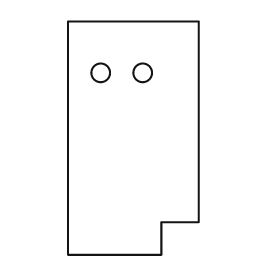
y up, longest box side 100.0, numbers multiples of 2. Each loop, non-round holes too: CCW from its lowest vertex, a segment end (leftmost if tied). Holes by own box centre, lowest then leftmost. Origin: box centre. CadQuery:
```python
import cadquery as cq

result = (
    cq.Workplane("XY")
    .moveTo(-28.0, -50.0)
    .lineTo(12.0, -50.0)
    .lineTo(12.0, -36.0)
    .lineTo(28.0, -36.0)
    .lineTo(28.0, 50.0)
    .lineTo(-28.0, 50.0)
    .close()
    .moveTo(-14.0, 28.0)
    .circle(4.0)
    .moveTo(4.0, 28.0)
    .circle(4.0)
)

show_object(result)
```